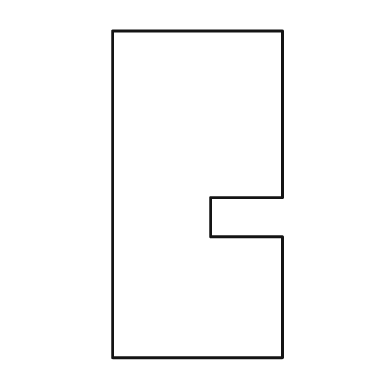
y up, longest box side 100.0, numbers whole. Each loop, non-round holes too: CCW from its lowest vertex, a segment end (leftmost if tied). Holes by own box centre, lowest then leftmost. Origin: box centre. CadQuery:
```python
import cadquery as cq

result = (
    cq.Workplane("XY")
    .moveTo(-26.0, -50.0)
    .lineTo(26.0, -50.0)
    .lineTo(26.0, -13.0)
    .lineTo(4.0, -13.0)
    .lineTo(4.0, -1.0)
    .lineTo(26.0, -1.0)
    .lineTo(26.0, 50.0)
    .lineTo(-26.0, 50.0)
    .close()
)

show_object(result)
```